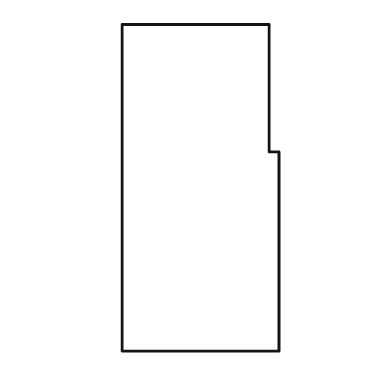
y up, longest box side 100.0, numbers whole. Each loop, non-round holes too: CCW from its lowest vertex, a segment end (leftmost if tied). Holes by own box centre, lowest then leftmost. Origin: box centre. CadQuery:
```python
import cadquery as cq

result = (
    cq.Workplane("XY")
    .moveTo(-24.0, -50.0)
    .lineTo(24.0, -50.0)
    .lineTo(24.0, 11.0)
    .lineTo(21.0, 11.0)
    .lineTo(21.0, 50.0)
    .lineTo(-24.0, 50.0)
    .close()
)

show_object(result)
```